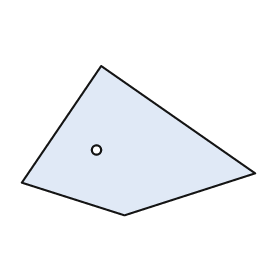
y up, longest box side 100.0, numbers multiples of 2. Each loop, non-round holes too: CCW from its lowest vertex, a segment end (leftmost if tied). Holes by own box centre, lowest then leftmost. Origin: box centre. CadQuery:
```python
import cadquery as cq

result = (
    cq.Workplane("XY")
    .moveTo(-6.0, -32.0)
    .lineTo(50.0, -14.0)
    .lineTo(-16.0, 32.0)
    .lineTo(-50.0, -18.0)
    .close()
    .moveTo(-18.0, -4.0)
    .circle(2.0)
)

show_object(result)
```